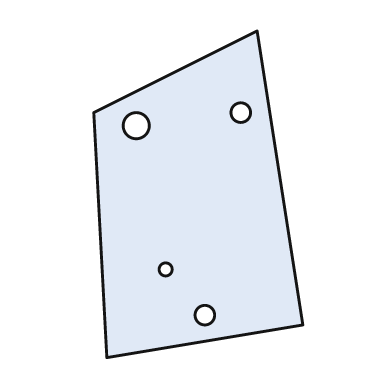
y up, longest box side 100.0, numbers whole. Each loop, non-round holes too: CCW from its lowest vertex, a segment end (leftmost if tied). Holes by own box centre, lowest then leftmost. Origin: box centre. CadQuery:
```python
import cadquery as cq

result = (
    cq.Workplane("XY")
    .moveTo(-28.0, -50.0)
    .lineTo(32.0, -40.0)
    .lineTo(18.0, 50.0)
    .lineTo(-32.0, 25.0)
    .close()
    .moveTo(2.0, -37.0)
    .circle(3.0)
    .moveTo(-10.0, -23.0)
    .circle(2.0)
    .moveTo(-19.0, 21.0)
    .circle(4.0)
    .moveTo(13.0, 25.0)
    .circle(3.0)
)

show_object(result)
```